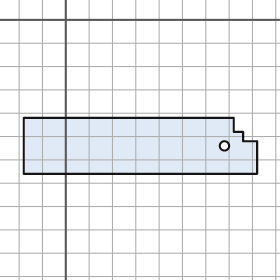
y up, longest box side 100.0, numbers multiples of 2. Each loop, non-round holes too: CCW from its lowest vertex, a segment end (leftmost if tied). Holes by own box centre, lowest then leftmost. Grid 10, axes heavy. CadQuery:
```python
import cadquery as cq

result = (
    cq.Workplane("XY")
    .moveTo(-18.0, -66.0)
    .lineTo(82.0, -66.0)
    .lineTo(82.0, -52.0)
    .lineTo(76.0, -52.0)
    .lineTo(76.0, -48.0)
    .lineTo(72.0, -48.0)
    .lineTo(72.0, -42.0)
    .lineTo(-18.0, -42.0)
    .close()
    .moveTo(68.0, -54.0)
    .circle(2.0)
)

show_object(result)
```